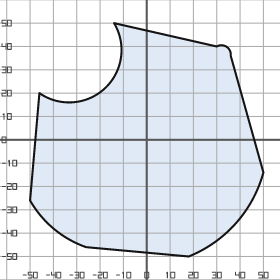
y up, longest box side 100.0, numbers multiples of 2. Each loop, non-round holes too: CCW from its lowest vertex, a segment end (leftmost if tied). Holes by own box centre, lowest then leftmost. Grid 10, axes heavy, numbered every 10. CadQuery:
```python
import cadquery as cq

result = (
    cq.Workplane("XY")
    .moveTo(18.0, -50.0)
    .threePointArc((38.0, -36.0), (50.0, -14.0))
    .lineTo(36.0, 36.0)
    .threePointArc((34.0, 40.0), (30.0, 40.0))
    .lineTo(-14.0, 50.0)
    .threePointArc((-18.0, 22.0), (-46.0, 20.0))
    .lineTo(-50.0, -26.0)
    .threePointArc((-40.0, -38.0), (-26.0, -46.0))
    .close()
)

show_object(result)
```